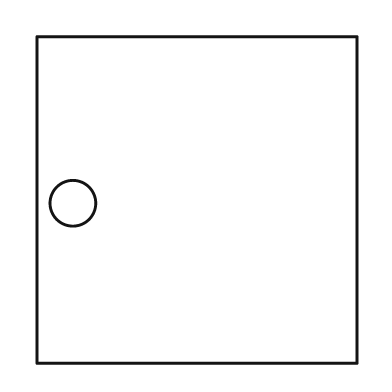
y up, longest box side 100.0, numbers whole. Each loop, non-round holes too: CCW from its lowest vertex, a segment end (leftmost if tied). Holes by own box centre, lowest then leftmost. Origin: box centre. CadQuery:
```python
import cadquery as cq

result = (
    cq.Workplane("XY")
    .moveTo(-49.0, -50.0)
    .lineTo(49.0, -50.0)
    .lineTo(49.0, 50.0)
    .lineTo(-49.0, 50.0)
    .close()
    .moveTo(-38.0, -1.0)
    .circle(7.0)
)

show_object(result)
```